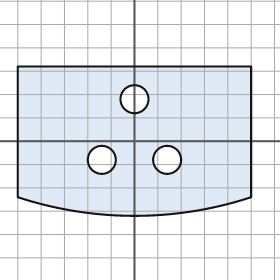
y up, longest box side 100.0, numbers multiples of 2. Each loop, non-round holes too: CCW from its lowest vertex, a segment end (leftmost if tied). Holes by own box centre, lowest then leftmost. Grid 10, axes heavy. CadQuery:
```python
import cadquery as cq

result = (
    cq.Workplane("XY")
    .moveTo(-50.0, -24.0)
    .threePointArc((0.0, -32.0), (50.0, -24.0))
    .lineTo(50.0, 32.0)
    .lineTo(-50.0, 32.0)
    .close()
    .moveTo(-14.0, -8.0)
    .circle(6.0)
    .moveTo(14.0, -8.0)
    .circle(6.0)
    .moveTo(0.0, 18.0)
    .circle(6.0)
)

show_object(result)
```